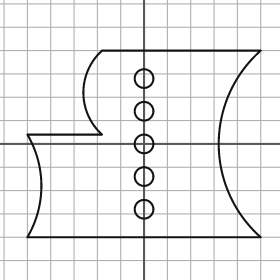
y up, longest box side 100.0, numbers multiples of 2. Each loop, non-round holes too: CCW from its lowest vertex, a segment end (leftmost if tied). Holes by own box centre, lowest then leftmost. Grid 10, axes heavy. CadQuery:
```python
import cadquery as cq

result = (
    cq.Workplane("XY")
    .moveTo(-50.0, -40.0)
    .lineTo(50.0, -40.0)
    .threePointArc((32.0, 0.0), (50.0, 40.0))
    .lineTo(-18.0, 40.0)
    .threePointArc((-26.0, 22.0), (-18.0, 4.0))
    .lineTo(-50.0, 4.0)
    .threePointArc((-44.0, -18.0), (-50.0, -40.0))
    .close()
    .moveTo(0.0, -28.0)
    .circle(4.0)
    .moveTo(0.0, -14.0)
    .circle(4.0)
    .moveTo(0.0, 0.0)
    .circle(4.0)
    .moveTo(0.0, 14.0)
    .circle(4.0)
    .moveTo(0.0, 28.0)
    .circle(4.0)
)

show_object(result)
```